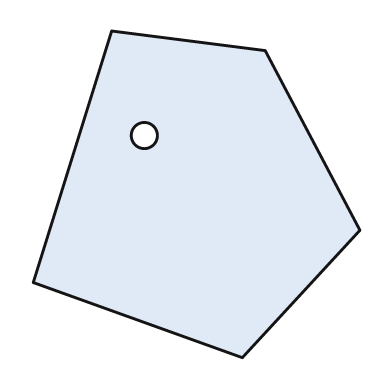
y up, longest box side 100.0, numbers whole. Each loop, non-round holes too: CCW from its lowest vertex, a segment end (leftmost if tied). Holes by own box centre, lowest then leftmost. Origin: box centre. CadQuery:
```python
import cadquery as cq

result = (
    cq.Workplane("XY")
    .moveTo(14.0, -50.0)
    .lineTo(50.0, -11.0)
    .lineTo(21.0, 44.0)
    .lineTo(-26.0, 50.0)
    .lineTo(-50.0, -27.0)
    .close()
    .moveTo(-16.0, 18.0)
    .circle(4.0)
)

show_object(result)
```